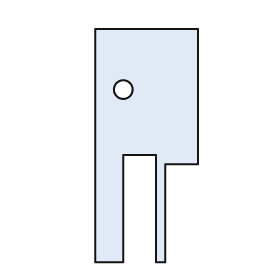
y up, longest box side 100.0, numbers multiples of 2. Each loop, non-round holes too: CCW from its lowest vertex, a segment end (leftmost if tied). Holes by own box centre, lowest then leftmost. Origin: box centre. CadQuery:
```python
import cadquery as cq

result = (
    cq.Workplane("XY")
    .moveTo(-22.0, -50.0)
    .lineTo(-10.0, -50.0)
    .lineTo(-10.0, -4.0)
    .lineTo(4.0, -4.0)
    .lineTo(4.0, -50.0)
    .lineTo(8.0, -50.0)
    .lineTo(8.0, -8.0)
    .lineTo(22.0, -8.0)
    .lineTo(22.0, 50.0)
    .lineTo(-22.0, 50.0)
    .close()
    .moveTo(-10.0, 24.0)
    .circle(4.0)
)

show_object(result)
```